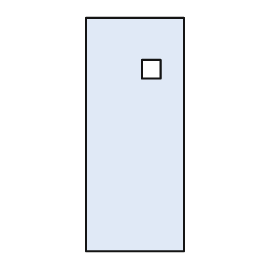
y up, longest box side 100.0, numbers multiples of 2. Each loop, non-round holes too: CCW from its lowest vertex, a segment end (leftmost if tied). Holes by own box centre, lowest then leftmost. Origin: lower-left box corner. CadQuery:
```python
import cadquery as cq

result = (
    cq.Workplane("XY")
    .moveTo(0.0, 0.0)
    .lineTo(42.0, 0.0)
    .lineTo(42.0, 100.0)
    .lineTo(0.0, 100.0)
    .close()
    .moveTo(24.0, 74.0)
    .lineTo(32.0, 74.0)
    .lineTo(32.0, 82.0)
    .lineTo(24.0, 82.0)
    .close()
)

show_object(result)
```